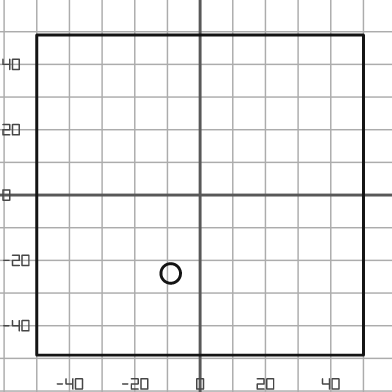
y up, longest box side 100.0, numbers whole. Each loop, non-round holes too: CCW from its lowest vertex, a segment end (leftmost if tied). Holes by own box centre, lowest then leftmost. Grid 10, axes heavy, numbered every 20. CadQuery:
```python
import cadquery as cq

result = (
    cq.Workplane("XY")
    .moveTo(-50.0, -49.0)
    .lineTo(50.0, -49.0)
    .lineTo(50.0, 49.0)
    .lineTo(-50.0, 49.0)
    .close()
    .moveTo(-9.0, -24.0)
    .circle(3.0)
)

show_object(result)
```